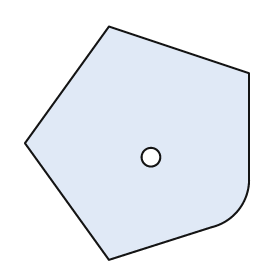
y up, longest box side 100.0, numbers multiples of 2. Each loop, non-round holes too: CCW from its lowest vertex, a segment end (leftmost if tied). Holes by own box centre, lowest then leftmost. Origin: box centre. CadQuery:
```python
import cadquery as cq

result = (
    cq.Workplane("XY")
    .moveTo(-12.0, -50.0)
    .lineTo(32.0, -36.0)
    .threePointArc((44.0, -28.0), (48.0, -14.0))
    .lineTo(48.0, 30.0)
    .lineTo(-12.0, 50.0)
    .lineTo(-48.0, 0.0)
    .close()
    .moveTo(6.0, -6.0)
    .circle(4.0)
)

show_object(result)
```